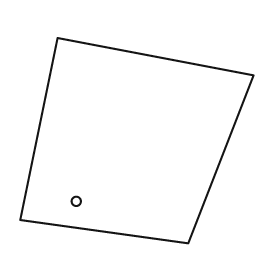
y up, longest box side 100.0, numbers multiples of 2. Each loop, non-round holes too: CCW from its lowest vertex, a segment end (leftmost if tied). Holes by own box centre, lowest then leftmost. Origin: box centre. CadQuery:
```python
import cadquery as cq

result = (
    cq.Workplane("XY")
    .moveTo(22.0, -44.0)
    .lineTo(50.0, 28.0)
    .lineTo(-34.0, 44.0)
    .lineTo(-50.0, -34.0)
    .close()
    .moveTo(-26.0, -26.0)
    .circle(2.0)
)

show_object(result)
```